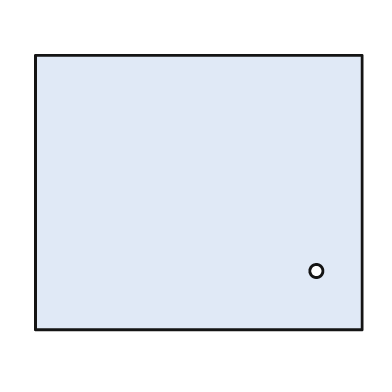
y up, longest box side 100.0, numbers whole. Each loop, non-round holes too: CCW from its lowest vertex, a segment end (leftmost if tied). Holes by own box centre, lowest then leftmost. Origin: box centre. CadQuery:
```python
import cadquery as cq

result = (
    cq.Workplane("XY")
    .moveTo(-50.0, -42.0)
    .lineTo(50.0, -42.0)
    .lineTo(50.0, 42.0)
    .lineTo(-50.0, 42.0)
    .close()
    .moveTo(36.0, -24.0)
    .circle(2.0)
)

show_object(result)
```